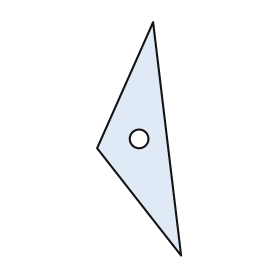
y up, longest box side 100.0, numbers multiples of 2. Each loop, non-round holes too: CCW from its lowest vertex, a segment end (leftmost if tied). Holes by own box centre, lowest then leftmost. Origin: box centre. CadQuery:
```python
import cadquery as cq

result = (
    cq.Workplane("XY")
    .moveTo(18.0, -50.0)
    .lineTo(6.0, 50.0)
    .lineTo(-18.0, -4.0)
    .close()
    .moveTo(0.0, 0.0)
    .circle(4.0)
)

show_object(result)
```